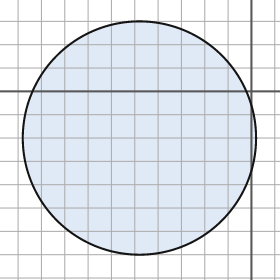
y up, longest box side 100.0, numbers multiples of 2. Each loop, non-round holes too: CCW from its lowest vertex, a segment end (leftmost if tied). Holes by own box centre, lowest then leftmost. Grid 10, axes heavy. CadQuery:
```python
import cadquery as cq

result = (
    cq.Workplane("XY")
    .moveTo(-48.0, -20.0)
    .circle(50.0)
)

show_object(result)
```